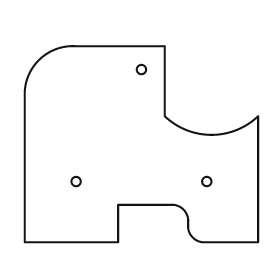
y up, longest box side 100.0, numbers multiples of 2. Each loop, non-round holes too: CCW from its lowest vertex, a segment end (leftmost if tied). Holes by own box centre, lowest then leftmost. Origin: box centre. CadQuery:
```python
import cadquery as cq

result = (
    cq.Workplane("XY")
    .moveTo(-50.0, -42.0)
    .lineTo(-10.0, -42.0)
    .lineTo(-10.0, -26.0)
    .lineTo(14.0, -26.0)
    .threePointArc((18.0, -28.0), (20.0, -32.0))
    .lineTo(20.0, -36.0)
    .threePointArc((22.0, -40.0), (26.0, -42.0))
    .lineTo(50.0, -42.0)
    .lineTo(50.0, 12.0)
    .threePointArc((30.0, 4.0), (10.0, 12.0))
    .lineTo(10.0, 42.0)
    .lineTo(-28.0, 42.0)
    .threePointArc((-44.0, 36.0), (-50.0, 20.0))
    .close()
    .moveTo(-28.0, -16.0)
    .circle(2.0)
    .moveTo(28.0, -16.0)
    .circle(2.0)
    .moveTo(0.0, 32.0)
    .circle(2.0)
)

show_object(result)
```